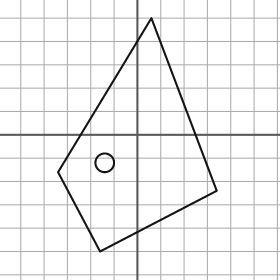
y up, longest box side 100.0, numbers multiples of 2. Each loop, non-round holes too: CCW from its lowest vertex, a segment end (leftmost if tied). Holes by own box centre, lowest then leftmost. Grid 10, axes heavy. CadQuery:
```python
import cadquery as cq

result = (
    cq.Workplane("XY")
    .moveTo(-16.0, -50.0)
    .lineTo(34.0, -24.0)
    .lineTo(6.0, 50.0)
    .lineTo(-34.0, -16.0)
    .close()
    .moveTo(-14.0, -12.0)
    .circle(4.0)
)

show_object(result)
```